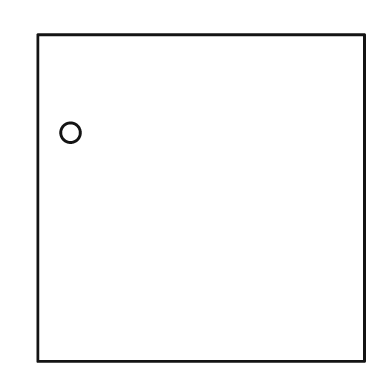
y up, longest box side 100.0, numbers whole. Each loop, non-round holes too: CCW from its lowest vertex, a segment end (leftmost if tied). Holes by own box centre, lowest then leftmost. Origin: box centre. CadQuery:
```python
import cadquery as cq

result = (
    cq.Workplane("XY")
    .moveTo(-50.0, -50.0)
    .lineTo(50.0, -50.0)
    .lineTo(50.0, 50.0)
    .lineTo(-50.0, 50.0)
    .close()
    .moveTo(-40.0, 20.0)
    .circle(3.0)
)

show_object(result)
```